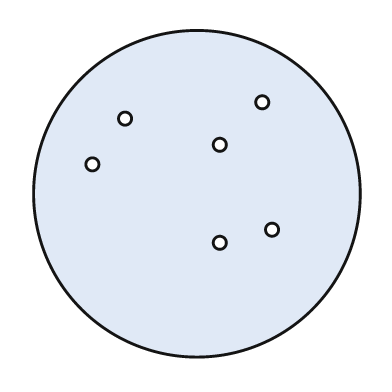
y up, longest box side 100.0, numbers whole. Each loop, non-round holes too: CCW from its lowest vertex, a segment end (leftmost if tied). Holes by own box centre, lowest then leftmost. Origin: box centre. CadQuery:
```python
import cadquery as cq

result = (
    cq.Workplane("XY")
    .moveTo(0.0, 0.0)
    .circle(50.0)
    .moveTo(7.0, -15.0)
    .circle(2.0)
    .moveTo(23.0, -11.0)
    .circle(2.0)
    .moveTo(-32.0, 9.0)
    .circle(2.0)
    .moveTo(7.0, 15.0)
    .circle(2.0)
    .moveTo(-22.0, 23.0)
    .circle(2.0)
    .moveTo(20.0, 28.0)
    .circle(2.0)
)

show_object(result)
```